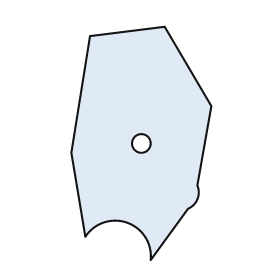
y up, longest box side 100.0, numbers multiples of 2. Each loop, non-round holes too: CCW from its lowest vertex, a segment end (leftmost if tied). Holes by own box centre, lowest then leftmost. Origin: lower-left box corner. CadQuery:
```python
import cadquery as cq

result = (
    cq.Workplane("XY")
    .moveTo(34.0, 0.0)
    .lineTo(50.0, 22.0)
    .threePointArc((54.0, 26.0), (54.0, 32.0))
    .lineTo(60.0, 66.0)
    .lineTo(40.0, 100.0)
    .lineTo(8.0, 96.0)
    .lineTo(0.0, 46.0)
    .lineTo(6.0, 10.0)
    .threePointArc((24.0, 16.0), (34.0, 0.0))
    .close()
    .moveTo(30.0, 50.0)
    .circle(4.0)
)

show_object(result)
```